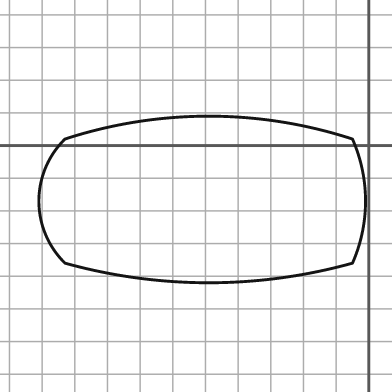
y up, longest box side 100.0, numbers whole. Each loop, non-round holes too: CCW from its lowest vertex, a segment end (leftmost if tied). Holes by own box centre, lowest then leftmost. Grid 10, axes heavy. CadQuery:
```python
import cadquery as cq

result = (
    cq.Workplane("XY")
    .moveTo(-93.0, -36.0)
    .threePointArc((-49.0, -42.0), (-5.0, -36.0))
    .threePointArc((-1.0, -17.0), (-5.0, 2.0))
    .threePointArc((-49.0, 9.0), (-93.0, 2.0))
    .threePointArc((-101.0, -17.0), (-93.0, -36.0))
    .close()
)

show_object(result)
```